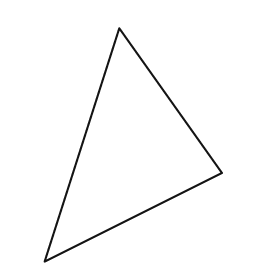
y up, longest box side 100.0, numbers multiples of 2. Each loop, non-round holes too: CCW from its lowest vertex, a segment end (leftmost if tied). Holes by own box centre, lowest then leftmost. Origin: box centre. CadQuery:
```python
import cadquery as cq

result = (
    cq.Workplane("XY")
    .moveTo(-38.0, -50.0)
    .lineTo(38.0, -12.0)
    .lineTo(-6.0, 50.0)
    .close()
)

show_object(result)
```